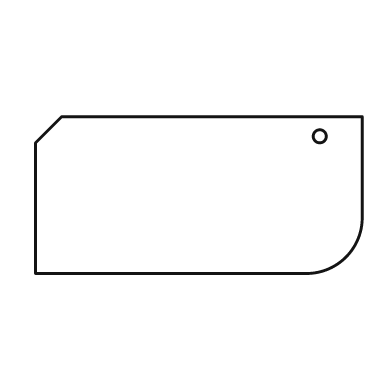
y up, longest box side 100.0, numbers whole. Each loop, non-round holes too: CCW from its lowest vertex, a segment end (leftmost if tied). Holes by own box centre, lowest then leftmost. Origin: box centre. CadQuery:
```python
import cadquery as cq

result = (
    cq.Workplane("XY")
    .moveTo(-50.0, -24.0)
    .lineTo(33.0, -24.0)
    .threePointArc((45.0, -19.0), (50.0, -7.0))
    .lineTo(50.0, 24.0)
    .lineTo(-42.0, 24.0)
    .lineTo(-50.0, 16.0)
    .close()
    .moveTo(37.0, 18.0)
    .circle(2.0)
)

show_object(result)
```